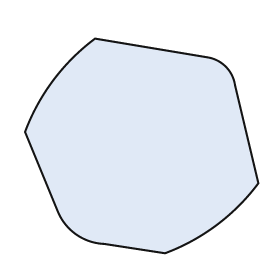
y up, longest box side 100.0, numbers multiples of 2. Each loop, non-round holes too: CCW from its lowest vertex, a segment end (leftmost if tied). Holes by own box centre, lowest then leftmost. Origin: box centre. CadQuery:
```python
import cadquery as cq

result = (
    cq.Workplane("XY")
    .moveTo(10.0, -46.0)
    .threePointArc((32.0, -34.0), (50.0, -16.0))
    .lineTo(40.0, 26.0)
    .threePointArc((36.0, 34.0), (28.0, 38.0))
    .lineTo(-20.0, 46.0)
    .threePointArc((-38.0, 28.0), (-50.0, 6.0))
    .lineTo(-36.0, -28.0)
    .threePointArc((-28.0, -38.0), (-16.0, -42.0))
    .close()
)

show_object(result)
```